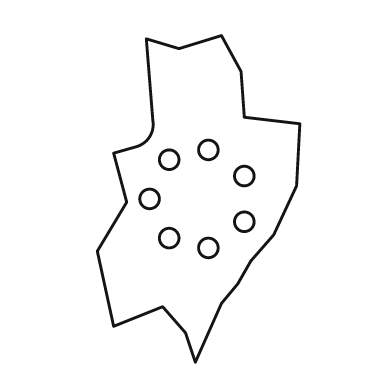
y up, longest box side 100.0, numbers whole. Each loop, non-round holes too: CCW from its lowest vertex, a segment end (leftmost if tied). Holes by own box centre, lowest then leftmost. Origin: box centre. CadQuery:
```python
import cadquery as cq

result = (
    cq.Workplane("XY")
    .moveTo(-1.0, -50.0)
    .lineTo(7.0, -32.0)
    .lineTo(12.0, -26.0)
    .lineTo(16.0, -19.0)
    .lineTo(23.0, -11.0)
    .lineTo(30.0, 4.0)
    .lineTo(31.0, 23.0)
    .lineTo(14.0, 25.0)
    .lineTo(13.0, 39.0)
    .lineTo(7.0, 50.0)
    .lineTo(-6.0, 46.0)
    .lineTo(-16.0, 49.0)
    .lineTo(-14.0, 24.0)
    .threePointArc((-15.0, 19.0), (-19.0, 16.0))
    .lineTo(-26.0, 14.0)
    .lineTo(-22.0, -1.0)
    .lineTo(-31.0, -16.0)
    .lineTo(-26.0, -39.0)
    .lineTo(-11.0, -33.0)
    .lineTo(-4.0, -41.0)
    .close()
    .moveTo(3.0, -15.0)
    .circle(3.0)
    .moveTo(-9.0, -12.0)
    .circle(3.0)
    .moveTo(14.0, -7.0)
    .circle(3.0)
    .moveTo(-15.0, 0.0)
    .circle(3.0)
    .moveTo(14.0, 7.0)
    .circle(3.0)
    .moveTo(-9.0, 12.0)
    .circle(3.0)
    .moveTo(3.0, 15.0)
    .circle(3.0)
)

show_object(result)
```